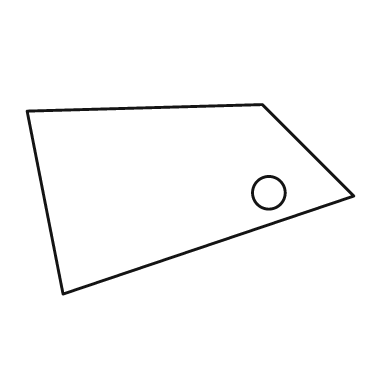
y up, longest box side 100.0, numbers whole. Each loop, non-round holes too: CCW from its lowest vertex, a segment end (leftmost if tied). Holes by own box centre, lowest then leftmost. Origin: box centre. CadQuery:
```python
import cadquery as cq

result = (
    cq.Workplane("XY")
    .moveTo(-39.0, -29.0)
    .lineTo(50.0, 1.0)
    .lineTo(22.0, 29.0)
    .lineTo(-50.0, 27.0)
    .close()
    .moveTo(24.0, 2.0)
    .circle(5.0)
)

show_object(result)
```